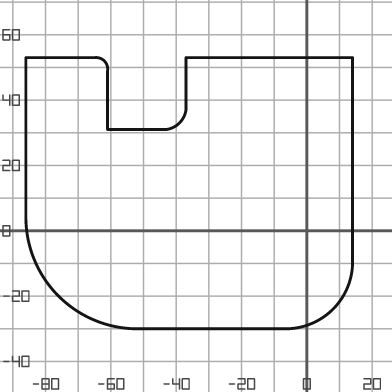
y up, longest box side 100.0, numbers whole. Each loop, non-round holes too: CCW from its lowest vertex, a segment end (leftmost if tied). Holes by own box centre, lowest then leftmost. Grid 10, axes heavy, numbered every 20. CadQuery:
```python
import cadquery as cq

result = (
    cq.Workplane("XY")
    .moveTo(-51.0, -30.0)
    .lineTo(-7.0, -30.0)
    .threePointArc((8.0, -24.0), (14.0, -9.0))
    .lineTo(14.0, 53.0)
    .lineTo(-37.0, 53.0)
    .lineTo(-37.0, 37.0)
    .threePointArc((-39.0, 33.0), (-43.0, 31.0))
    .lineTo(-61.0, 31.0)
    .lineTo(-61.0, 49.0)
    .threePointArc((-62.0, 52.0), (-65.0, 53.0))
    .lineTo(-86.0, 53.0)
    .lineTo(-86.0, 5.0)
    .threePointArc((-76.0, -20.0), (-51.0, -30.0))
    .close()
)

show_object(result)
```